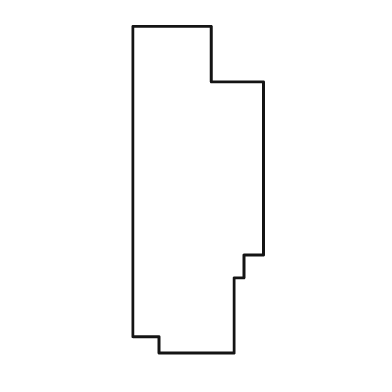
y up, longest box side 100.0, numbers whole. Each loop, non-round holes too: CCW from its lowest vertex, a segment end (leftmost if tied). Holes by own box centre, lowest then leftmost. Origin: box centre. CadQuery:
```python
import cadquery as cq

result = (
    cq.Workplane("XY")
    .moveTo(-12.0, -50.0)
    .lineTo(11.0, -50.0)
    .lineTo(11.0, -27.0)
    .lineTo(14.0, -27.0)
    .lineTo(14.0, -20.0)
    .lineTo(20.0, -20.0)
    .lineTo(20.0, 33.0)
    .lineTo(4.0, 33.0)
    .lineTo(4.0, 50.0)
    .lineTo(-20.0, 50.0)
    .lineTo(-20.0, -45.0)
    .lineTo(-12.0, -45.0)
    .close()
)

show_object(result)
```